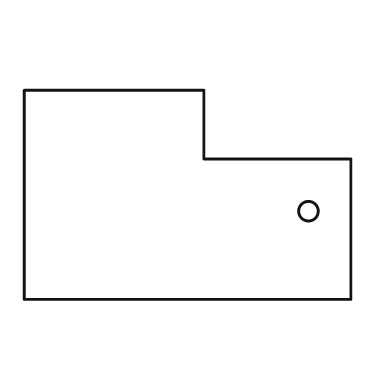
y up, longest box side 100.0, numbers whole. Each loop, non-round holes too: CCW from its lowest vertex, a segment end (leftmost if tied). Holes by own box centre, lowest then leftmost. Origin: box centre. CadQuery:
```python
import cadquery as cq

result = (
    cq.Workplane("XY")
    .moveTo(-50.0, -32.0)
    .lineTo(50.0, -32.0)
    .lineTo(50.0, 11.0)
    .lineTo(5.0, 11.0)
    .lineTo(5.0, 32.0)
    .lineTo(-50.0, 32.0)
    .close()
    .moveTo(37.0, -5.0)
    .circle(3.0)
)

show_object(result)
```